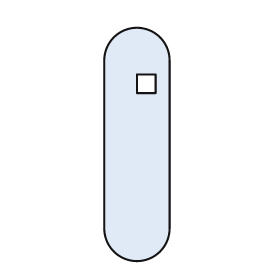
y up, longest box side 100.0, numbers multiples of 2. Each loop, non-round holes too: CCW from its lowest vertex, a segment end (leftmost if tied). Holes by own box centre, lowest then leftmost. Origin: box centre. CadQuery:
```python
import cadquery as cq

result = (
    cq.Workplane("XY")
    .moveTo(-14.0, -36.0)
    .threePointArc((0.0, -50.0), (14.0, -36.0))
    .lineTo(14.0, 36.0)
    .threePointArc((0.0, 50.0), (-14.0, 36.0))
    .close()
    .moveTo(0.0, 22.0)
    .lineTo(8.0, 22.0)
    .lineTo(8.0, 30.0)
    .lineTo(0.0, 30.0)
    .close()
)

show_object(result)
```